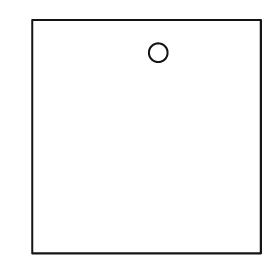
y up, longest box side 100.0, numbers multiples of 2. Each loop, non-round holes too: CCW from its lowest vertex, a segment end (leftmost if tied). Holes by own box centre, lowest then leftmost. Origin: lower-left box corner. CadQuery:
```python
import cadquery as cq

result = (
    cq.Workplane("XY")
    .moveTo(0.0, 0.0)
    .lineTo(98.0, 0.0)
    .lineTo(98.0, 100.0)
    .lineTo(0.0, 100.0)
    .close()
    .moveTo(54.0, 86.0)
    .circle(4.0)
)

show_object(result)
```